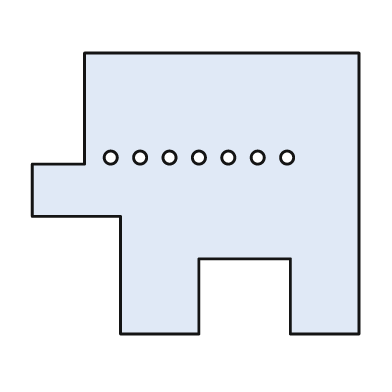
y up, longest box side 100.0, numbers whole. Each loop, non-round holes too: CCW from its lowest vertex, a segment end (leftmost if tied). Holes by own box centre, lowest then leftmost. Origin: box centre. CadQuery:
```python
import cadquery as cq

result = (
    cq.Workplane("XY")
    .moveTo(-23.0, -43.0)
    .lineTo(1.0, -43.0)
    .lineTo(1.0, -20.0)
    .lineTo(29.0, -20.0)
    .lineTo(29.0, -43.0)
    .lineTo(50.0, -43.0)
    .lineTo(50.0, 43.0)
    .lineTo(-34.0, 43.0)
    .lineTo(-34.0, 9.0)
    .lineTo(-50.0, 9.0)
    .lineTo(-50.0, -7.0)
    .lineTo(-23.0, -7.0)
    .close()
    .moveTo(-26.0, 11.0)
    .circle(2.0)
    .moveTo(-17.0, 11.0)
    .circle(2.0)
    .moveTo(-8.0, 11.0)
    .circle(2.0)
    .moveTo(1.0, 11.0)
    .circle(2.0)
    .moveTo(10.0, 11.0)
    .circle(2.0)
    .moveTo(19.0, 11.0)
    .circle(2.0)
    .moveTo(28.0, 11.0)
    .circle(2.0)
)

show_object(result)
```